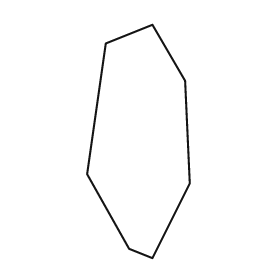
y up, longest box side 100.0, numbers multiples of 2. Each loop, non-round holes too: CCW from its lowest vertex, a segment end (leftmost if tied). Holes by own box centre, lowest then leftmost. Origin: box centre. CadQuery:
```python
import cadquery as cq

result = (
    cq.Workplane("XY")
    .moveTo(6.0, -50.0)
    .lineTo(22.0, -18.0)
    .lineTo(20.0, 26.0)
    .lineTo(6.0, 50.0)
    .lineTo(-14.0, 42.0)
    .lineTo(-22.0, -14.0)
    .lineTo(-4.0, -46.0)
    .close()
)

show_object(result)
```